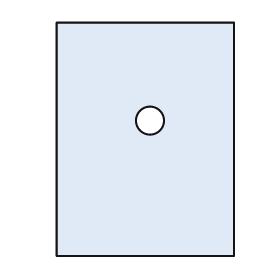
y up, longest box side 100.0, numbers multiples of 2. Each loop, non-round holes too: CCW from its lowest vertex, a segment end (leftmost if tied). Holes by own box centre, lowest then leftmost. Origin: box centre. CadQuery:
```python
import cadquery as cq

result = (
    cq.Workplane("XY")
    .moveTo(-38.0, -50.0)
    .lineTo(38.0, -50.0)
    .lineTo(38.0, 50.0)
    .lineTo(-38.0, 50.0)
    .close()
    .moveTo(2.0, 8.0)
    .circle(6.0)
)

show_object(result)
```